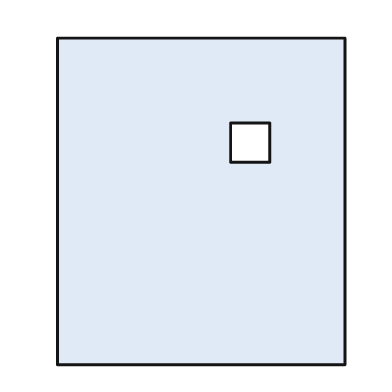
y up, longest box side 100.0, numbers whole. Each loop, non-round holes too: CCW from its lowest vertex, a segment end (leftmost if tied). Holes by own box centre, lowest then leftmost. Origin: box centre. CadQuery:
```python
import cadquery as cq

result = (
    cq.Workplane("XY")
    .moveTo(-44.0, -50.0)
    .lineTo(44.0, -50.0)
    .lineTo(44.0, 50.0)
    .lineTo(-44.0, 50.0)
    .close()
    .moveTo(9.0, 12.0)
    .lineTo(21.0, 12.0)
    .lineTo(21.0, 24.0)
    .lineTo(9.0, 24.0)
    .close()
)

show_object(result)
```